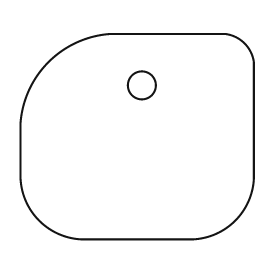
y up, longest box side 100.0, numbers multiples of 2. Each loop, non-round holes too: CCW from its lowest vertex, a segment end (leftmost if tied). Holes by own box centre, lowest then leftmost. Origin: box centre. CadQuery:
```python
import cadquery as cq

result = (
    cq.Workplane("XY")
    .moveTo(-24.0, -44.0)
    .lineTo(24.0, -44.0)
    .threePointArc((42.0, -36.0), (50.0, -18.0))
    .lineTo(50.0, 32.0)
    .threePointArc((46.0, 40.0), (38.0, 44.0))
    .lineTo(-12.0, 44.0)
    .threePointArc((-38.0, 32.0), (-50.0, 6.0))
    .lineTo(-50.0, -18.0)
    .threePointArc((-42.0, -36.0), (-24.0, -44.0))
    .close()
    .moveTo(2.0, 22.0)
    .circle(6.0)
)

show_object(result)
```